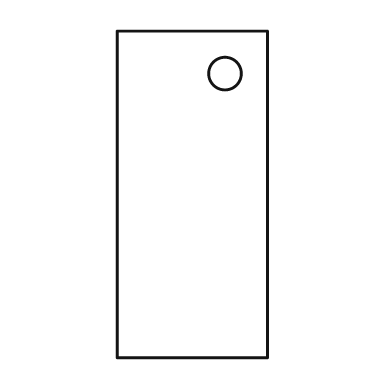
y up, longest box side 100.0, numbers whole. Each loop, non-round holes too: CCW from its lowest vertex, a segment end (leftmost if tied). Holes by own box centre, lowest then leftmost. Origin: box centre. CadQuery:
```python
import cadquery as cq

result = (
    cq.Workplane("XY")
    .moveTo(-23.0, -50.0)
    .lineTo(23.0, -50.0)
    .lineTo(23.0, 50.0)
    .lineTo(-23.0, 50.0)
    .close()
    .moveTo(10.0, 37.0)
    .circle(5.0)
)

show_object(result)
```